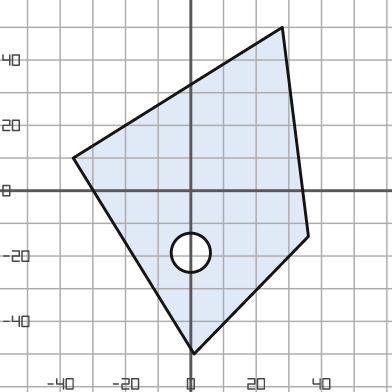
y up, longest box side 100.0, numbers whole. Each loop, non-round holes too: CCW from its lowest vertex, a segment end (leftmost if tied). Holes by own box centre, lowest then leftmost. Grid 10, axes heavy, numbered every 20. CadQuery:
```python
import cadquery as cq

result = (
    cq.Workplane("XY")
    .moveTo(1.0, -50.0)
    .lineTo(36.0, -14.0)
    .lineTo(28.0, 50.0)
    .lineTo(-36.0, 10.0)
    .close()
    .moveTo(0.0, -19.0)
    .circle(6.0)
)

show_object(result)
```